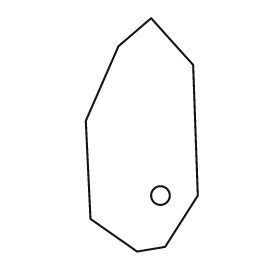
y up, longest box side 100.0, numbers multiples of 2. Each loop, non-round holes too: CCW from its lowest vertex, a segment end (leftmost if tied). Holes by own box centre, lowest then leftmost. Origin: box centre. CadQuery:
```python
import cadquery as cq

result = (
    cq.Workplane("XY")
    .moveTo(-2.0, -50.0)
    .lineTo(10.0, -48.0)
    .lineTo(24.0, -26.0)
    .lineTo(22.0, 30.0)
    .lineTo(4.0, 50.0)
    .lineTo(-10.0, 38.0)
    .lineTo(-24.0, 6.0)
    .lineTo(-22.0, -36.0)
    .close()
    .moveTo(8.0, -26.0)
    .circle(4.0)
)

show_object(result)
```